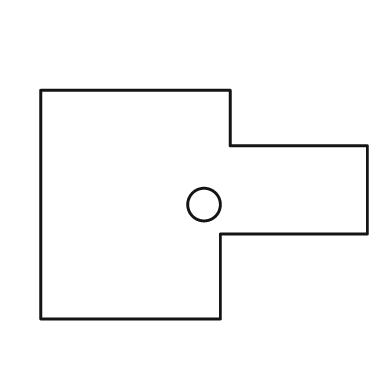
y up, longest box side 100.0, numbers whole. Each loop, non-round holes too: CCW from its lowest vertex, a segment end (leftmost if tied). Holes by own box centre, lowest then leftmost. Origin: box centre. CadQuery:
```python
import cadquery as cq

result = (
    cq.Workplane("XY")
    .moveTo(-50.0, -35.0)
    .lineTo(5.0, -35.0)
    .lineTo(5.0, -9.0)
    .lineTo(50.0, -9.0)
    .lineTo(50.0, 18.0)
    .lineTo(8.0, 18.0)
    .lineTo(8.0, 35.0)
    .lineTo(-50.0, 35.0)
    .close()
    .moveTo(0.0, 0.0)
    .circle(5.0)
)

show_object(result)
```